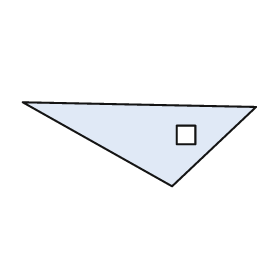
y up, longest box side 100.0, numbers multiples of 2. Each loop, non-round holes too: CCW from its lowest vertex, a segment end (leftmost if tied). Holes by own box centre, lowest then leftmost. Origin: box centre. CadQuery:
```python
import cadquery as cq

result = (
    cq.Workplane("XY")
    .moveTo(14.0, -18.0)
    .lineTo(50.0, 16.0)
    .lineTo(-50.0, 18.0)
    .close()
    .moveTo(16.0, 0.0)
    .lineTo(24.0, 0.0)
    .lineTo(24.0, 8.0)
    .lineTo(16.0, 8.0)
    .close()
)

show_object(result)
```